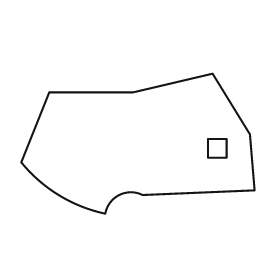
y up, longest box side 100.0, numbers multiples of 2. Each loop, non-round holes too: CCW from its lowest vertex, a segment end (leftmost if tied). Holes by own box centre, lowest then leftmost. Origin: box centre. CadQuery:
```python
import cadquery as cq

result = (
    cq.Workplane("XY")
    .moveTo(-14.0, -30.0)
    .threePointArc((-8.0, -22.0), (2.0, -22.0))
    .lineTo(50.0, -20.0)
    .lineTo(48.0, 4.0)
    .lineTo(32.0, 30.0)
    .lineTo(-2.0, 22.0)
    .lineTo(-38.0, 22.0)
    .lineTo(-50.0, -8.0)
    .threePointArc((-34.0, -22.0), (-14.0, -30.0))
    .close()
    .moveTo(30.0, -6.0)
    .lineTo(38.0, -6.0)
    .lineTo(38.0, 2.0)
    .lineTo(30.0, 2.0)
    .close()
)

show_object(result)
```